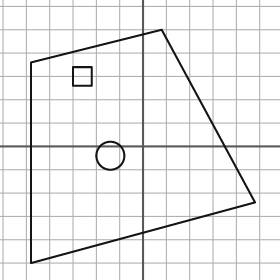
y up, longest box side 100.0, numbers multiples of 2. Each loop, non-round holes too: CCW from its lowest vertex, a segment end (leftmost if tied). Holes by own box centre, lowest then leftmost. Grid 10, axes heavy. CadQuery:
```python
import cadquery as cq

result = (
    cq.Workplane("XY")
    .moveTo(-48.0, -50.0)
    .lineTo(48.0, -24.0)
    .lineTo(8.0, 50.0)
    .lineTo(-48.0, 36.0)
    .close()
    .moveTo(-14.0, -4.0)
    .circle(6.0)
    .moveTo(-30.0, 26.0)
    .lineTo(-22.0, 26.0)
    .lineTo(-22.0, 34.0)
    .lineTo(-30.0, 34.0)
    .close()
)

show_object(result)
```